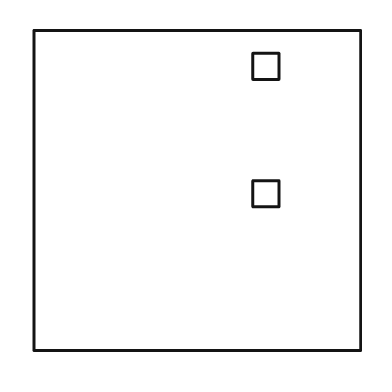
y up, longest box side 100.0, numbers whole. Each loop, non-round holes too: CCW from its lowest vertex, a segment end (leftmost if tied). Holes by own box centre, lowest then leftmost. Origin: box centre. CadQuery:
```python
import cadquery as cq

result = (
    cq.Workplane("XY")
    .moveTo(-50.0, -49.0)
    .lineTo(50.0, -49.0)
    .lineTo(50.0, 49.0)
    .lineTo(-50.0, 49.0)
    .close()
    .moveTo(17.0, -5.0)
    .lineTo(25.0, -5.0)
    .lineTo(25.0, 3.0)
    .lineTo(17.0, 3.0)
    .close()
    .moveTo(17.0, 34.0)
    .lineTo(25.0, 34.0)
    .lineTo(25.0, 42.0)
    .lineTo(17.0, 42.0)
    .close()
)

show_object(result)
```